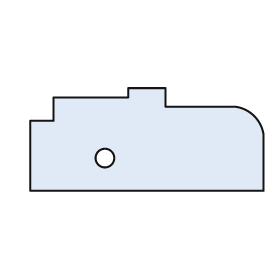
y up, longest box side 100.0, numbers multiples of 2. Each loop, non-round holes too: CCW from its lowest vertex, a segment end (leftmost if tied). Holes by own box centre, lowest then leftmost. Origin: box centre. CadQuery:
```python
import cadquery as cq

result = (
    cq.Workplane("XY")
    .moveTo(-50.0, -22.0)
    .lineTo(50.0, -22.0)
    .lineTo(50.0, 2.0)
    .threePointArc((46.0, 10.0), (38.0, 14.0))
    .lineTo(8.0, 14.0)
    .lineTo(8.0, 22.0)
    .lineTo(-8.0, 22.0)
    .lineTo(-8.0, 18.0)
    .lineTo(-40.0, 18.0)
    .lineTo(-40.0, 8.0)
    .lineTo(-50.0, 8.0)
    .close()
    .moveTo(-18.0, -8.0)
    .circle(4.0)
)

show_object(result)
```